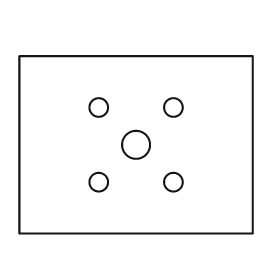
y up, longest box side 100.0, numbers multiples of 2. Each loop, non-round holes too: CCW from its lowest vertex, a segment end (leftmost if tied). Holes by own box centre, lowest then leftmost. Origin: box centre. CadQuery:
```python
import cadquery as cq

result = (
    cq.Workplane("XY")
    .moveTo(-50.0, -38.0)
    .lineTo(50.0, -38.0)
    .lineTo(50.0, 38.0)
    .lineTo(-50.0, 38.0)
    .close()
    .moveTo(-16.0, -16.0)
    .circle(4.0)
    .moveTo(16.0, -16.0)
    .circle(4.0)
    .moveTo(0.0, 0.0)
    .circle(6.0)
    .moveTo(-16.0, 16.0)
    .circle(4.0)
    .moveTo(16.0, 16.0)
    .circle(4.0)
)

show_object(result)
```